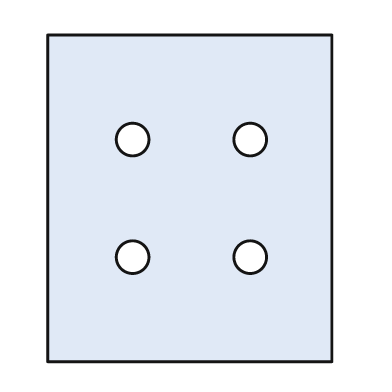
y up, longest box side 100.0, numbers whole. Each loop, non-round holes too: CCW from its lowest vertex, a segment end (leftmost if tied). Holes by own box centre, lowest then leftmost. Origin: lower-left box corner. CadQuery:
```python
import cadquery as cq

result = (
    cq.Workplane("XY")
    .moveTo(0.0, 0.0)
    .lineTo(87.0, 0.0)
    .lineTo(87.0, 100.0)
    .lineTo(0.0, 100.0)
    .close()
    .moveTo(26.0, 32.0)
    .circle(5.0)
    .moveTo(62.0, 32.0)
    .circle(5.0)
    .moveTo(26.0, 68.0)
    .circle(5.0)
    .moveTo(62.0, 68.0)
    .circle(5.0)
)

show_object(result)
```